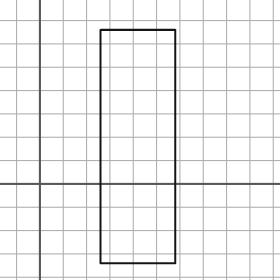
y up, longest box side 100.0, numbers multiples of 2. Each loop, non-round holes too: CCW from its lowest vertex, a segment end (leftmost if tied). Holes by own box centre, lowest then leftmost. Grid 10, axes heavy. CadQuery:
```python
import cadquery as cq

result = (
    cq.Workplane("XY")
    .moveTo(26.0, -34.0)
    .lineTo(58.0, -34.0)
    .lineTo(58.0, 66.0)
    .lineTo(26.0, 66.0)
    .close()
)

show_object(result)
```